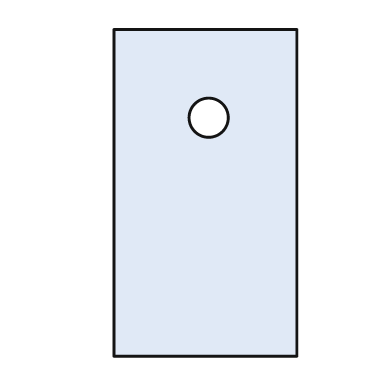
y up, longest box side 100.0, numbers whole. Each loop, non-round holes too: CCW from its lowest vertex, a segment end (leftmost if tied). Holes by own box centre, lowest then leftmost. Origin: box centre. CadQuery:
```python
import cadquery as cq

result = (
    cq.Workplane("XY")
    .moveTo(-28.0, -50.0)
    .lineTo(28.0, -50.0)
    .lineTo(28.0, 50.0)
    .lineTo(-28.0, 50.0)
    .close()
    .moveTo(1.0, 23.0)
    .circle(6.0)
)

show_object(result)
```